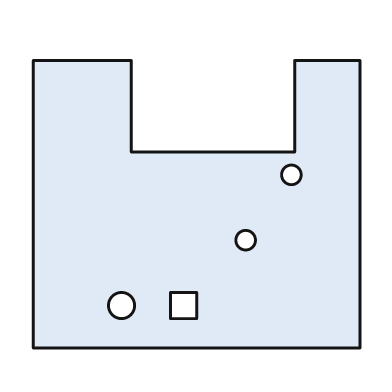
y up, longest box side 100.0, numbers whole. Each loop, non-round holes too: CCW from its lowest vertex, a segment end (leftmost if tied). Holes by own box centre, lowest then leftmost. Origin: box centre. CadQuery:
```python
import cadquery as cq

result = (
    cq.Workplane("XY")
    .moveTo(-50.0, -44.0)
    .lineTo(50.0, -44.0)
    .lineTo(50.0, 44.0)
    .lineTo(30.0, 44.0)
    .lineTo(30.0, 16.0)
    .lineTo(-20.0, 16.0)
    .lineTo(-20.0, 44.0)
    .lineTo(-50.0, 44.0)
    .close()
    .moveTo(-23.0, -31.0)
    .circle(4.0)
    .moveTo(-8.0, -35.0)
    .lineTo(0.0, -35.0)
    .lineTo(0.0, -27.0)
    .lineTo(-8.0, -27.0)
    .close()
    .moveTo(15.0, -11.0)
    .circle(3.0)
    .moveTo(29.0, 9.0)
    .circle(3.0)
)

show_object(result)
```